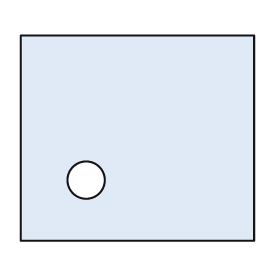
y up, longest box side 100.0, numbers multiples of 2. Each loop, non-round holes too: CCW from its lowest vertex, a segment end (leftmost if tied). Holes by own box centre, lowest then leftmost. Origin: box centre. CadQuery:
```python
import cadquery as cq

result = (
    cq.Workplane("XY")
    .moveTo(-50.0, -44.0)
    .lineTo(50.0, -44.0)
    .lineTo(50.0, 44.0)
    .lineTo(-50.0, 44.0)
    .close()
    .moveTo(-22.0, -18.0)
    .circle(8.0)
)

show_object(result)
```